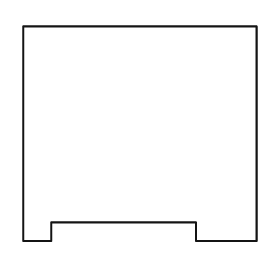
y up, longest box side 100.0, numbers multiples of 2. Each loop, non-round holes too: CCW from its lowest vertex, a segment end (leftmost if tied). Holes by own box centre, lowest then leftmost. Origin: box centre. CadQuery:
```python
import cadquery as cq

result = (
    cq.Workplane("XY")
    .moveTo(-50.0, -46.0)
    .lineTo(-38.0, -46.0)
    .lineTo(-38.0, -38.0)
    .lineTo(24.0, -38.0)
    .lineTo(24.0, -46.0)
    .lineTo(50.0, -46.0)
    .lineTo(50.0, 46.0)
    .lineTo(-50.0, 46.0)
    .close()
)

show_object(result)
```